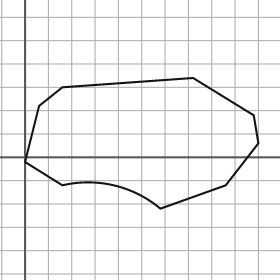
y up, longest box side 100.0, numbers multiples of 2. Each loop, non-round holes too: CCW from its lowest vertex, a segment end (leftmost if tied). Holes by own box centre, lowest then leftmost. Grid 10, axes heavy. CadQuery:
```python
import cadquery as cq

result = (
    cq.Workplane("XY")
    .moveTo(58.0, -22.0)
    .lineTo(86.0, -12.0)
    .lineTo(100.0, 6.0)
    .lineTo(98.0, 18.0)
    .lineTo(72.0, 34.0)
    .lineTo(16.0, 30.0)
    .lineTo(6.0, 22.0)
    .lineTo(0.0, -2.0)
    .lineTo(16.0, -12.0)
    .threePointArc((38.0, -12.0), (58.0, -22.0))
    .close()
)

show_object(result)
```